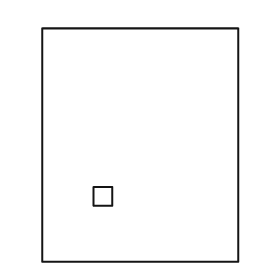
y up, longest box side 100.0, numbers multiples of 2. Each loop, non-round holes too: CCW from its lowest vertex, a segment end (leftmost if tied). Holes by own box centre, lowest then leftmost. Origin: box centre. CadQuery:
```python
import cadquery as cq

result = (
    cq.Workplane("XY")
    .moveTo(-42.0, -50.0)
    .lineTo(42.0, -50.0)
    .lineTo(42.0, 50.0)
    .lineTo(-42.0, 50.0)
    .close()
    .moveTo(-20.0, -26.0)
    .lineTo(-12.0, -26.0)
    .lineTo(-12.0, -18.0)
    .lineTo(-20.0, -18.0)
    .close()
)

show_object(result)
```